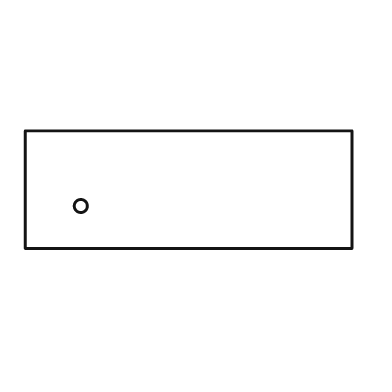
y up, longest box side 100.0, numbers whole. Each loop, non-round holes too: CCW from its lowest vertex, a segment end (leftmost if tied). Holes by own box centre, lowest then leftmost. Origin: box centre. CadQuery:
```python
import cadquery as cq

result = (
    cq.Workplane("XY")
    .moveTo(-50.0, -18.0)
    .lineTo(50.0, -18.0)
    .lineTo(50.0, 18.0)
    .lineTo(-50.0, 18.0)
    .close()
    .moveTo(-33.0, -5.0)
    .circle(2.0)
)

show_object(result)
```